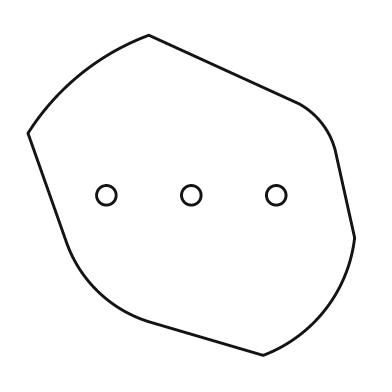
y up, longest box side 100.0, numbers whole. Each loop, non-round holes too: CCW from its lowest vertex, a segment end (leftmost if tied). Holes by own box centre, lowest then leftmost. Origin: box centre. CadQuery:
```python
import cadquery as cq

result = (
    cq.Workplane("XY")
    .moveTo(22.0, -49.0)
    .threePointArc((41.0, -35.0), (50.0, -13.0))
    .lineTo(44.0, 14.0)
    .threePointArc((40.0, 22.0), (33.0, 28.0))
    .lineTo(-13.0, 49.0)
    .threePointArc((-34.0, 37.0), (-50.0, 19.0))
    .lineTo(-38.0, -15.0)
    .threePointArc((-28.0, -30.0), (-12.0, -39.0))
    .close()
    .moveTo(-26.0, 0.0)
    .circle(3.0)
    .moveTo(0.0, 0.0)
    .circle(3.0)
    .moveTo(26.0, 0.0)
    .circle(3.0)
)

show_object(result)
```